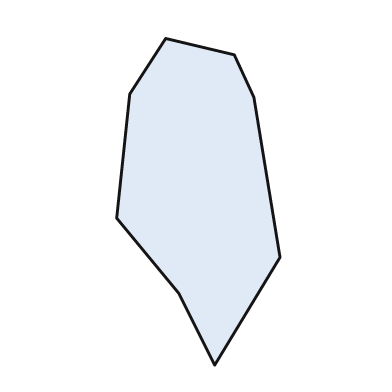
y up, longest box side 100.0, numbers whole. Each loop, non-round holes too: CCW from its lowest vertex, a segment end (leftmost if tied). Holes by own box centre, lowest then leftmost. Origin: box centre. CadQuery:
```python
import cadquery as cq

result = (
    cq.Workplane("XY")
    .moveTo(5.0, -50.0)
    .lineTo(25.0, -17.0)
    .lineTo(17.0, 32.0)
    .lineTo(11.0, 45.0)
    .lineTo(-10.0, 50.0)
    .lineTo(-21.0, 33.0)
    .lineTo(-25.0, -5.0)
    .lineTo(-6.0, -28.0)
    .close()
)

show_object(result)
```